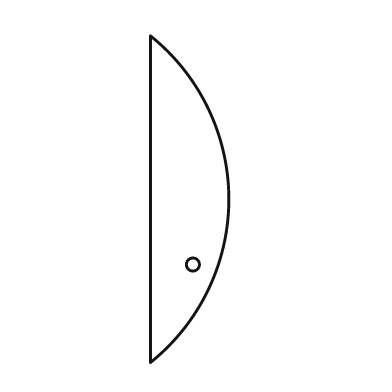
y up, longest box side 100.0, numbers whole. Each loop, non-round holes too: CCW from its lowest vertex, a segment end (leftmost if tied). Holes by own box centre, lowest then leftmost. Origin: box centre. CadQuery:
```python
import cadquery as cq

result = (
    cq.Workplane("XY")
    .moveTo(-12.0, -50.0)
    .threePointArc((12.0, 0.0), (-12.0, 50.0))
    .close()
    .moveTo(1.0, -20.0)
    .circle(2.0)
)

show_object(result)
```